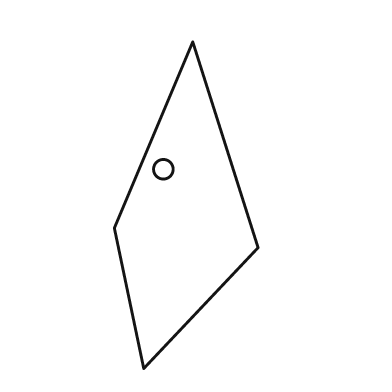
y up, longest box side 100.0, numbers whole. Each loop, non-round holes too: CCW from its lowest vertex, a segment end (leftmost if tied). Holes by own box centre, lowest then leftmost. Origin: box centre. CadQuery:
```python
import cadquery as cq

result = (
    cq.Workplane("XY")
    .moveTo(-13.0, -50.0)
    .lineTo(22.0, -13.0)
    .lineTo(2.0, 50.0)
    .lineTo(-22.0, -7.0)
    .close()
    .moveTo(-7.0, 11.0)
    .circle(3.0)
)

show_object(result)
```